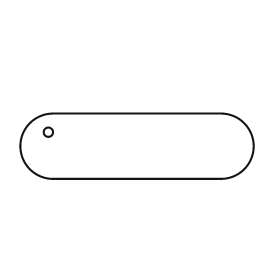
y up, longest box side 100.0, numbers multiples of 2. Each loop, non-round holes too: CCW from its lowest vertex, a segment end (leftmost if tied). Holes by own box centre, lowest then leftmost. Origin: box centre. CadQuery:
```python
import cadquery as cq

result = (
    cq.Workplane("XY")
    .moveTo(-36.0, -14.0)
    .lineTo(36.0, -14.0)
    .threePointArc((50.0, 0.0), (36.0, 14.0))
    .lineTo(-36.0, 14.0)
    .threePointArc((-50.0, 0.0), (-36.0, -14.0))
    .close()
    .moveTo(-38.0, 6.0)
    .circle(2.0)
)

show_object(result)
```